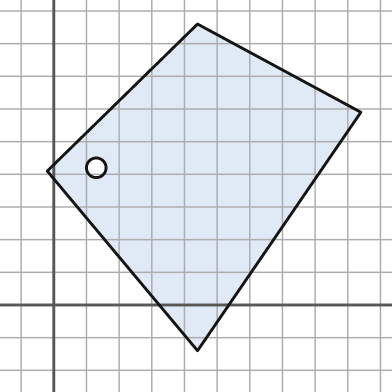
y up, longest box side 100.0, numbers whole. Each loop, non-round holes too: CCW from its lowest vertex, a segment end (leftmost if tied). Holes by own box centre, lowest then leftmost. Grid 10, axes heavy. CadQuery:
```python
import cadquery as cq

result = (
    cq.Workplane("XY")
    .moveTo(44.0, -14.0)
    .lineTo(94.0, 59.0)
    .lineTo(44.0, 86.0)
    .lineTo(-2.0, 41.0)
    .close()
    .moveTo(13.0, 42.0)
    .circle(3.0)
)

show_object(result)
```